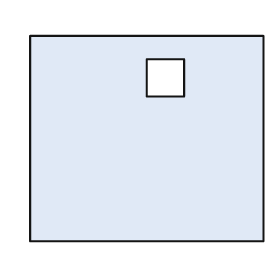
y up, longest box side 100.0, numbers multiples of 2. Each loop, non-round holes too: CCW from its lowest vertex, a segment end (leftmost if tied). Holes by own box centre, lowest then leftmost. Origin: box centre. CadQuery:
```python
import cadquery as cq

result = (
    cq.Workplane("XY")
    .moveTo(-50.0, -44.0)
    .lineTo(50.0, -44.0)
    .lineTo(50.0, 44.0)
    .lineTo(-50.0, 44.0)
    .close()
    .moveTo(0.0, 18.0)
    .lineTo(16.0, 18.0)
    .lineTo(16.0, 34.0)
    .lineTo(0.0, 34.0)
    .close()
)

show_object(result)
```